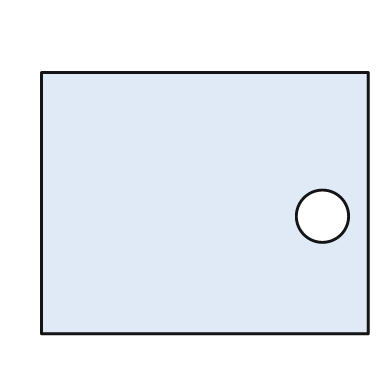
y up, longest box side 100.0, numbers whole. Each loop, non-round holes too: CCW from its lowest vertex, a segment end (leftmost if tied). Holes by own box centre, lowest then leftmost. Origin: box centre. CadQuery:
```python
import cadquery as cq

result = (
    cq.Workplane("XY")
    .moveTo(-50.0, -40.0)
    .lineTo(50.0, -40.0)
    .lineTo(50.0, 40.0)
    .lineTo(-50.0, 40.0)
    .close()
    .moveTo(36.0, -4.0)
    .circle(8.0)
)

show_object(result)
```